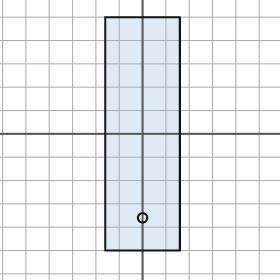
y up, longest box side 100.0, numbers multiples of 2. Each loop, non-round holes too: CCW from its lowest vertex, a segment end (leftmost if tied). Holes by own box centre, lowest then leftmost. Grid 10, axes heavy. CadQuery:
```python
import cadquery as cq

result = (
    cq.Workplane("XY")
    .moveTo(-16.0, -50.0)
    .lineTo(16.0, -50.0)
    .lineTo(16.0, 50.0)
    .lineTo(-16.0, 50.0)
    .close()
    .moveTo(0.0, -36.0)
    .circle(2.0)
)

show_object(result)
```